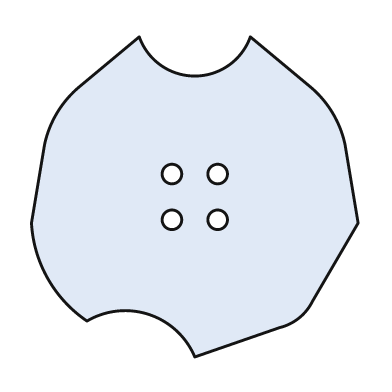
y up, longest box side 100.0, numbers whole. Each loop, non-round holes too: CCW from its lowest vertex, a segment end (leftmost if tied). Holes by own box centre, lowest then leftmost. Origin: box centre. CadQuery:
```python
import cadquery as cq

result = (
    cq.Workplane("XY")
    .moveTo(0.0, -49.0)
    .lineTo(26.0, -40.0)
    .threePointArc((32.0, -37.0), (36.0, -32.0))
    .lineTo(50.0, -8.0)
    .lineTo(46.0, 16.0)
    .threePointArc((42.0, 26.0), (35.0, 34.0))
    .lineTo(17.0, 49.0)
    .threePointArc((0.0, 37.0), (-17.0, 49.0))
    .lineTo(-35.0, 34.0)
    .threePointArc((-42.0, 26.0), (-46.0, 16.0))
    .lineTo(-50.0, -8.0)
    .threePointArc((-45.0, -25.0), (-33.0, -38.0))
    .threePointArc((-14.0, -36.0), (0.0, -49.0))
    .close()
    .moveTo(-7.0, -7.0)
    .circle(3.0)
    .moveTo(7.0, -7.0)
    .circle(3.0)
    .moveTo(-7.0, 7.0)
    .circle(3.0)
    .moveTo(7.0, 7.0)
    .circle(3.0)
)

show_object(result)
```